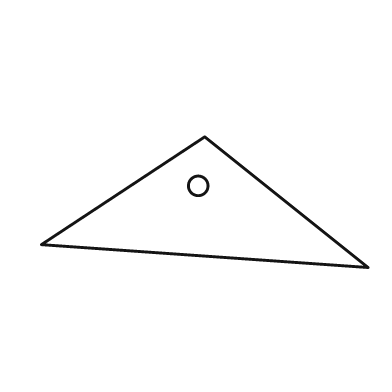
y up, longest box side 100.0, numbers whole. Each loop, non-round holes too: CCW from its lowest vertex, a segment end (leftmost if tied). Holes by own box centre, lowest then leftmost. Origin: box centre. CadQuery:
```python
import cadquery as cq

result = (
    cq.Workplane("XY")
    .moveTo(50.0, -20.0)
    .lineTo(0.0, 20.0)
    .lineTo(-50.0, -13.0)
    .close()
    .moveTo(-2.0, 5.0)
    .circle(3.0)
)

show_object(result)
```